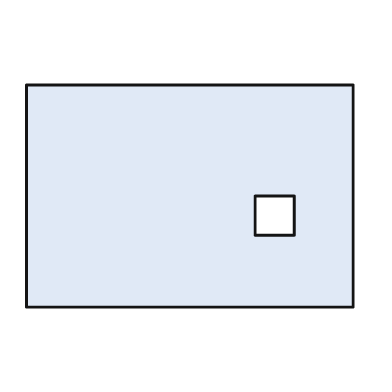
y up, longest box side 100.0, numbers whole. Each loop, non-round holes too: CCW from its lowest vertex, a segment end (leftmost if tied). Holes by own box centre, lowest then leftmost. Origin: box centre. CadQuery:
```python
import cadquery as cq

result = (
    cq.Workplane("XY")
    .moveTo(-50.0, -34.0)
    .lineTo(50.0, -34.0)
    .lineTo(50.0, 34.0)
    .lineTo(-50.0, 34.0)
    .close()
    .moveTo(20.0, -12.0)
    .lineTo(32.0, -12.0)
    .lineTo(32.0, 0.0)
    .lineTo(20.0, 0.0)
    .close()
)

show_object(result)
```